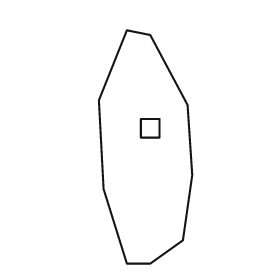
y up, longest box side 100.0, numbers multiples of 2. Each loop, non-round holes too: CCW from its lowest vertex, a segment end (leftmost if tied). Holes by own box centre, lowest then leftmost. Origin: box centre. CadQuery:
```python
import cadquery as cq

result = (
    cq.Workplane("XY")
    .moveTo(-8.0, -50.0)
    .lineTo(2.0, -50.0)
    .lineTo(16.0, -40.0)
    .lineTo(20.0, -12.0)
    .lineTo(18.0, 18.0)
    .lineTo(2.0, 48.0)
    .lineTo(-8.0, 50.0)
    .lineTo(-20.0, 20.0)
    .lineTo(-18.0, -18.0)
    .close()
    .moveTo(-2.0, 4.0)
    .lineTo(6.0, 4.0)
    .lineTo(6.0, 12.0)
    .lineTo(-2.0, 12.0)
    .close()
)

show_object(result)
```